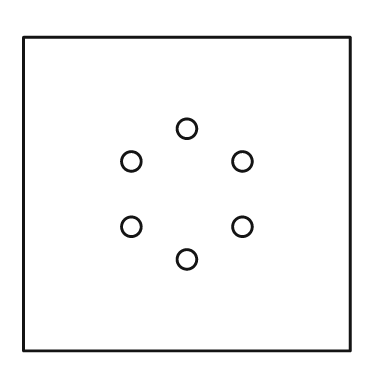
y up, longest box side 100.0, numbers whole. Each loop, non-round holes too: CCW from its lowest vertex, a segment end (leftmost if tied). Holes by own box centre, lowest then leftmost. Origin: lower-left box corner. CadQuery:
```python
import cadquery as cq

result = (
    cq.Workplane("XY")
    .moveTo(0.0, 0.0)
    .lineTo(100.0, 0.0)
    .lineTo(100.0, 96.0)
    .lineTo(0.0, 96.0)
    .close()
    .moveTo(50.0, 28.0)
    .circle(3.0)
    .moveTo(33.0, 38.0)
    .circle(3.0)
    .moveTo(67.0, 38.0)
    .circle(3.0)
    .moveTo(33.0, 58.0)
    .circle(3.0)
    .moveTo(67.0, 58.0)
    .circle(3.0)
    .moveTo(50.0, 68.0)
    .circle(3.0)
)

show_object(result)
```